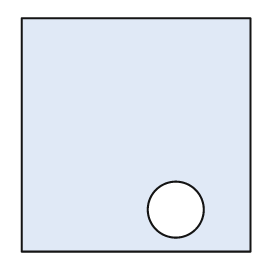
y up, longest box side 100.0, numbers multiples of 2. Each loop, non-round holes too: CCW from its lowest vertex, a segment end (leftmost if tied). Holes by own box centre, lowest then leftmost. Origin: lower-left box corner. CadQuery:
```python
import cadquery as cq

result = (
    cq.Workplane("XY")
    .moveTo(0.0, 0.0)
    .lineTo(98.0, 0.0)
    .lineTo(98.0, 100.0)
    .lineTo(0.0, 100.0)
    .close()
    .moveTo(66.0, 18.0)
    .circle(12.0)
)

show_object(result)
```